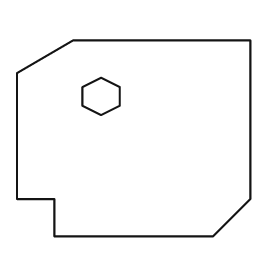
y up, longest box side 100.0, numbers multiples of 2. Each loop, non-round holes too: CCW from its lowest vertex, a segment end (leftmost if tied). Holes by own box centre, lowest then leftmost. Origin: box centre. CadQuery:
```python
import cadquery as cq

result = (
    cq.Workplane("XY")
    .moveTo(-34.0, -42.0)
    .lineTo(34.0, -42.0)
    .lineTo(50.0, -26.0)
    .lineTo(50.0, 42.0)
    .lineTo(-26.0, 42.0)
    .lineTo(-50.0, 28.0)
    .lineTo(-50.0, -26.0)
    .lineTo(-34.0, -26.0)
    .close()
    .moveTo(-14.0, 10.0)
    .lineTo(-6.0, 14.0)
    .lineTo(-6.0, 22.0)
    .lineTo(-14.0, 26.0)
    .lineTo(-22.0, 22.0)
    .lineTo(-22.0, 14.0)
    .close()
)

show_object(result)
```